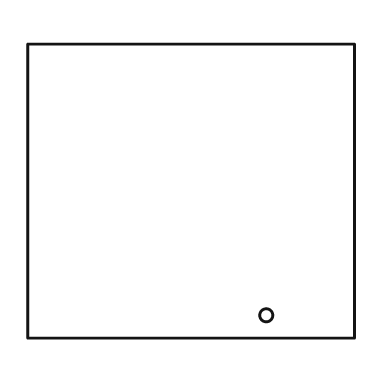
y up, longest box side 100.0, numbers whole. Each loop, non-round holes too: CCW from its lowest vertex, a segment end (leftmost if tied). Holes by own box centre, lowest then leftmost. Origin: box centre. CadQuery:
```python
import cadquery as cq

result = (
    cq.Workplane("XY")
    .moveTo(-50.0, -45.0)
    .lineTo(50.0, -45.0)
    .lineTo(50.0, 45.0)
    .lineTo(-50.0, 45.0)
    .close()
    .moveTo(23.0, -38.0)
    .circle(2.0)
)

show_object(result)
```